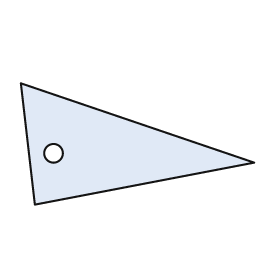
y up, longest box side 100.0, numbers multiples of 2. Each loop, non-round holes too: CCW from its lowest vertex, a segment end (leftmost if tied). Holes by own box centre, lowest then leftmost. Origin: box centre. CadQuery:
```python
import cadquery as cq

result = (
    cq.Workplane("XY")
    .moveTo(-44.0, -26.0)
    .lineTo(50.0, -8.0)
    .lineTo(-50.0, 26.0)
    .close()
    .moveTo(-36.0, -4.0)
    .circle(4.0)
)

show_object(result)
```